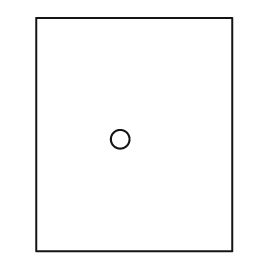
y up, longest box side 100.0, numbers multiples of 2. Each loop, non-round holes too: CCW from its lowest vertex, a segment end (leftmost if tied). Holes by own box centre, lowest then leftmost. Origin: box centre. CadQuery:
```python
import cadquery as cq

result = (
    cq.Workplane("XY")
    .moveTo(-42.0, -50.0)
    .lineTo(42.0, -50.0)
    .lineTo(42.0, 50.0)
    .lineTo(-42.0, 50.0)
    .close()
    .moveTo(-6.0, -2.0)
    .circle(4.0)
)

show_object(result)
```